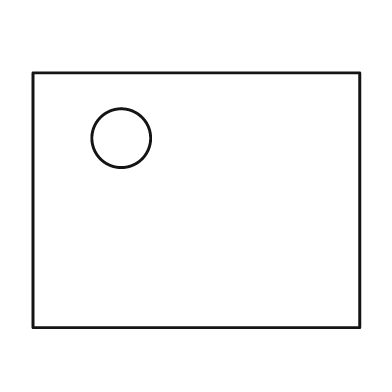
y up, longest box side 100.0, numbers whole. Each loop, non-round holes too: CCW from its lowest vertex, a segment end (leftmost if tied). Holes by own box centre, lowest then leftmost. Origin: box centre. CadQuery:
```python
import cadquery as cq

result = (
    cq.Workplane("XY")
    .moveTo(-50.0, -39.0)
    .lineTo(50.0, -39.0)
    .lineTo(50.0, 39.0)
    .lineTo(-50.0, 39.0)
    .close()
    .moveTo(-23.0, 19.0)
    .circle(9.0)
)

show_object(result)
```